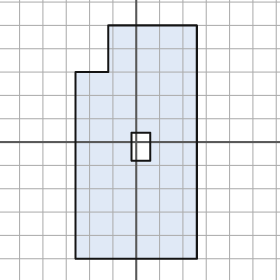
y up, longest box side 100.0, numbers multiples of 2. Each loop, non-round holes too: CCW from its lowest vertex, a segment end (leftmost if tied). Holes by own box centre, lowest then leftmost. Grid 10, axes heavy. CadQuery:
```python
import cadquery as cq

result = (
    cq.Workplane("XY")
    .moveTo(-26.0, -50.0)
    .lineTo(26.0, -50.0)
    .lineTo(26.0, 50.0)
    .lineTo(-12.0, 50.0)
    .lineTo(-12.0, 30.0)
    .lineTo(-26.0, 30.0)
    .close()
    .moveTo(-2.0, -8.0)
    .lineTo(6.0, -8.0)
    .lineTo(6.0, 4.0)
    .lineTo(-2.0, 4.0)
    .close()
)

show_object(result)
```